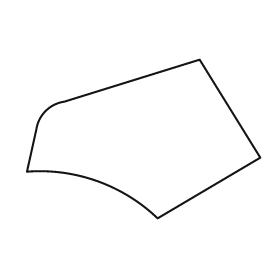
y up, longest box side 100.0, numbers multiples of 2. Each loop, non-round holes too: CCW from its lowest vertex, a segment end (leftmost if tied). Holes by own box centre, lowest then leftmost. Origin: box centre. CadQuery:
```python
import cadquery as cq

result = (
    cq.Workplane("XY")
    .moveTo(6.0, -34.0)
    .lineTo(50.0, -8.0)
    .lineTo(24.0, 34.0)
    .lineTo(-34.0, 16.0)
    .threePointArc((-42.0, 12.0), (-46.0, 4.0))
    .lineTo(-50.0, -14.0)
    .threePointArc((-20.0, -18.0), (6.0, -34.0))
    .close()
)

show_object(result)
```